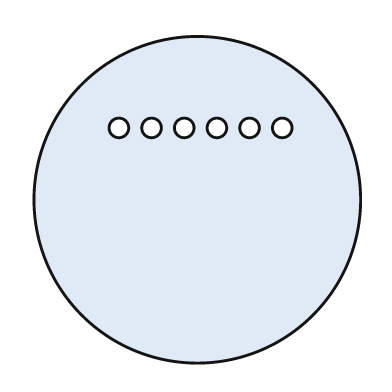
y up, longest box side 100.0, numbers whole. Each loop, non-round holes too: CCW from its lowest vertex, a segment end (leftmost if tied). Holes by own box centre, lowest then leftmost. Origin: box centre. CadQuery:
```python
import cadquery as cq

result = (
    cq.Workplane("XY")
    .moveTo(0.0, 0.0)
    .circle(50.0)
    .moveTo(-24.0, 22.0)
    .circle(3.0)
    .moveTo(-14.0, 22.0)
    .circle(3.0)
    .moveTo(-4.0, 22.0)
    .circle(3.0)
    .moveTo(6.0, 22.0)
    .circle(3.0)
    .moveTo(16.0, 22.0)
    .circle(3.0)
    .moveTo(26.0, 22.0)
    .circle(3.0)
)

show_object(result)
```